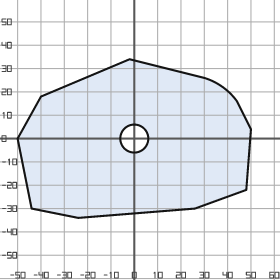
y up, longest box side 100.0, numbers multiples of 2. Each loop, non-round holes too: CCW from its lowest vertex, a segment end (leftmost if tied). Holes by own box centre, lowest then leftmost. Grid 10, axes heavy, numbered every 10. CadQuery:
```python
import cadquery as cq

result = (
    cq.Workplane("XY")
    .moveTo(-24.0, -34.0)
    .lineTo(26.0, -30.0)
    .lineTo(48.0, -22.0)
    .lineTo(50.0, 4.0)
    .lineTo(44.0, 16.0)
    .threePointArc((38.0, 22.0), (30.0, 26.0))
    .lineTo(-2.0, 34.0)
    .lineTo(-40.0, 18.0)
    .lineTo(-50.0, 0.0)
    .lineTo(-44.0, -30.0)
    .close()
    .moveTo(0.0, 0.0)
    .circle(6.0)
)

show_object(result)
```